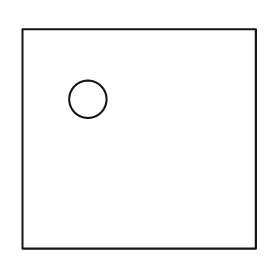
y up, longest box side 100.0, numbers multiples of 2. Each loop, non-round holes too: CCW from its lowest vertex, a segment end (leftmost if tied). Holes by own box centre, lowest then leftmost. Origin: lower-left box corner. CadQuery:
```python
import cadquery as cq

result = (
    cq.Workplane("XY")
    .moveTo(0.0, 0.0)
    .lineTo(100.0, 0.0)
    .lineTo(100.0, 94.0)
    .lineTo(0.0, 94.0)
    .close()
    .moveTo(28.0, 64.0)
    .circle(8.0)
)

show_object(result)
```